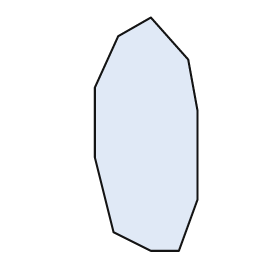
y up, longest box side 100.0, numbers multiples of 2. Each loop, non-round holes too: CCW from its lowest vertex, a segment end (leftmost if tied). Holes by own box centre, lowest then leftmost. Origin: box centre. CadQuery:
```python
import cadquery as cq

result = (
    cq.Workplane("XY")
    .moveTo(2.0, -50.0)
    .lineTo(14.0, -50.0)
    .lineTo(22.0, -28.0)
    .lineTo(22.0, 10.0)
    .lineTo(18.0, 32.0)
    .lineTo(2.0, 50.0)
    .lineTo(-12.0, 42.0)
    .lineTo(-22.0, 20.0)
    .lineTo(-22.0, -10.0)
    .lineTo(-14.0, -42.0)
    .close()
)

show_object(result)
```